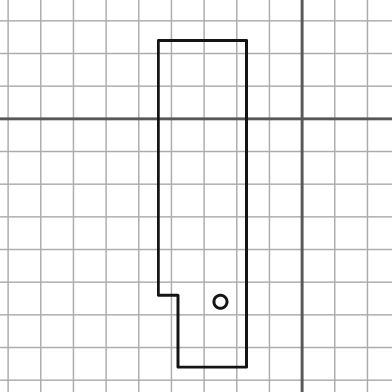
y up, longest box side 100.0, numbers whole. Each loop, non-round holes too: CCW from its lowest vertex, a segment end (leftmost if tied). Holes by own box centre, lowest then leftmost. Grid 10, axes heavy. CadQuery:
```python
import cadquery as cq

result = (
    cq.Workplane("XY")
    .moveTo(-38.0, -76.0)
    .lineTo(-17.0, -76.0)
    .lineTo(-17.0, 24.0)
    .lineTo(-44.0, 24.0)
    .lineTo(-44.0, -54.0)
    .lineTo(-38.0, -54.0)
    .close()
    .moveTo(-25.0, -56.0)
    .circle(2.0)
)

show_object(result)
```